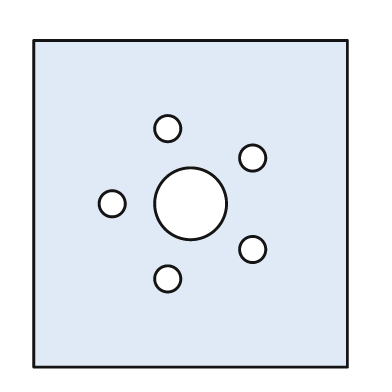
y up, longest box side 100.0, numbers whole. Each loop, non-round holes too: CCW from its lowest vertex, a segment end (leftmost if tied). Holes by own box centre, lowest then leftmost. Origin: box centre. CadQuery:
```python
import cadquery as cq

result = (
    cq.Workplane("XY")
    .moveTo(-48.0, -50.0)
    .lineTo(48.0, -50.0)
    .lineTo(48.0, 50.0)
    .lineTo(-48.0, 50.0)
    .close()
    .moveTo(-7.0, -23.0)
    .circle(4.0)
    .moveTo(19.0, -14.0)
    .circle(4.0)
    .moveTo(-24.0, 0.0)
    .circle(4.0)
    .moveTo(0.0, 0.0)
    .circle(11.0)
    .moveTo(19.0, 14.0)
    .circle(4.0)
    .moveTo(-7.0, 23.0)
    .circle(4.0)
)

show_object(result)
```